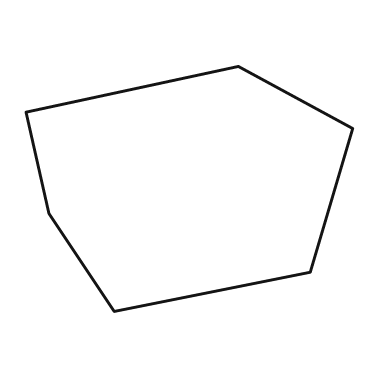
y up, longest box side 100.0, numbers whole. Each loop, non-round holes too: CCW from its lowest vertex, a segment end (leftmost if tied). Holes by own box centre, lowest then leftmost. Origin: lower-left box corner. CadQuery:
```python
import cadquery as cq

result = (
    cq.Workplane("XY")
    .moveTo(27.0, 0.0)
    .lineTo(87.0, 12.0)
    .lineTo(100.0, 56.0)
    .lineTo(65.0, 75.0)
    .lineTo(0.0, 61.0)
    .lineTo(7.0, 30.0)
    .close()
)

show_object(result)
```